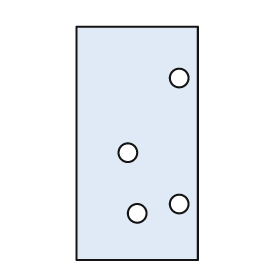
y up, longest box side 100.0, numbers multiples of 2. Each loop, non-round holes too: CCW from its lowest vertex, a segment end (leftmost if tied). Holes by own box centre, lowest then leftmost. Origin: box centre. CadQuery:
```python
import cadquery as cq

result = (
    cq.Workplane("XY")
    .moveTo(-26.0, -50.0)
    .lineTo(26.0, -50.0)
    .lineTo(26.0, 50.0)
    .lineTo(-26.0, 50.0)
    .close()
    .moveTo(0.0, -30.0)
    .circle(4.0)
    .moveTo(18.0, -26.0)
    .circle(4.0)
    .moveTo(-4.0, -4.0)
    .circle(4.0)
    .moveTo(18.0, 28.0)
    .circle(4.0)
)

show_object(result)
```